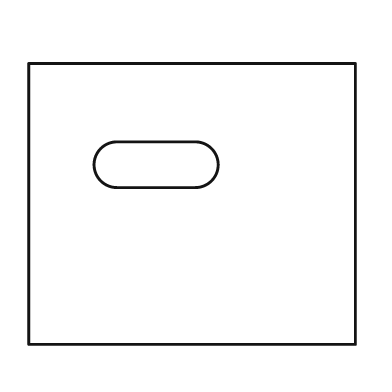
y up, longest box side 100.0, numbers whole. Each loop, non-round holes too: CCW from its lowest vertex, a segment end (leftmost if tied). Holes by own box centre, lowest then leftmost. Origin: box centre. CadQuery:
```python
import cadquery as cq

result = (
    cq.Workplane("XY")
    .moveTo(-50.0, -43.0)
    .lineTo(50.0, -43.0)
    .lineTo(50.0, 43.0)
    .lineTo(-50.0, 43.0)
    .close()
    .moveTo(-23.0, 5.0)
    .lineTo(1.0, 5.0)
    .threePointArc((8.0, 12.0), (1.0, 19.0))
    .lineTo(-23.0, 19.0)
    .threePointArc((-30.0, 12.0), (-23.0, 5.0))
    .close()
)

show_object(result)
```